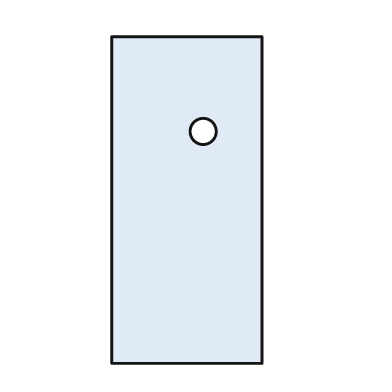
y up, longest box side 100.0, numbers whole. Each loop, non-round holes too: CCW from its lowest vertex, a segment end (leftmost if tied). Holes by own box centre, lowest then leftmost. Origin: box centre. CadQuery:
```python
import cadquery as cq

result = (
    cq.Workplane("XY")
    .moveTo(-23.0, -50.0)
    .lineTo(23.0, -50.0)
    .lineTo(23.0, 50.0)
    .lineTo(-23.0, 50.0)
    .close()
    .moveTo(5.0, 21.0)
    .circle(4.0)
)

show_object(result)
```